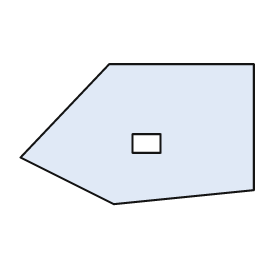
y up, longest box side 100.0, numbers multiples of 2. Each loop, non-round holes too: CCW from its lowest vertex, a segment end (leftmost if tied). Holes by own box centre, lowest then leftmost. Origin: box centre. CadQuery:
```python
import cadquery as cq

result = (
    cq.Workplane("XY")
    .moveTo(-10.0, -30.0)
    .lineTo(50.0, -24.0)
    .lineTo(50.0, 30.0)
    .lineTo(-12.0, 30.0)
    .lineTo(-50.0, -10.0)
    .close()
    .moveTo(-2.0, -8.0)
    .lineTo(10.0, -8.0)
    .lineTo(10.0, 0.0)
    .lineTo(-2.0, 0.0)
    .close()
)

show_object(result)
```